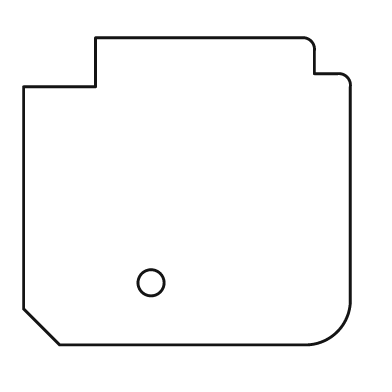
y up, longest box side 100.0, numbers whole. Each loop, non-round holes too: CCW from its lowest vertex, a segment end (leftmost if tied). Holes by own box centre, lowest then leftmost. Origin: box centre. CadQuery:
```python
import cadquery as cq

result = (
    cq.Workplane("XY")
    .moveTo(-39.0, -47.0)
    .lineTo(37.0, -47.0)
    .threePointArc((46.0, -43.0), (50.0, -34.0))
    .lineTo(50.0, 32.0)
    .threePointArc((49.0, 35.0), (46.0, 36.0))
    .lineTo(39.0, 36.0)
    .lineTo(39.0, 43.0)
    .threePointArc((38.0, 46.0), (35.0, 47.0))
    .lineTo(-28.0, 47.0)
    .lineTo(-28.0, 32.0)
    .lineTo(-50.0, 32.0)
    .lineTo(-50.0, -36.0)
    .close()
    .moveTo(-11.0, -28.0)
    .circle(4.0)
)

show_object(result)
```